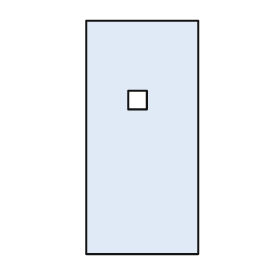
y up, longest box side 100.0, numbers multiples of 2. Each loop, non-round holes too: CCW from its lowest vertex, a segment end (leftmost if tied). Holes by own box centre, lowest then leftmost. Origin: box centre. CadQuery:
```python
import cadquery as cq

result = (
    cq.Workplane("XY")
    .moveTo(-24.0, -50.0)
    .lineTo(24.0, -50.0)
    .lineTo(24.0, 50.0)
    .lineTo(-24.0, 50.0)
    .close()
    .moveTo(-6.0, 12.0)
    .lineTo(2.0, 12.0)
    .lineTo(2.0, 20.0)
    .lineTo(-6.0, 20.0)
    .close()
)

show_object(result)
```